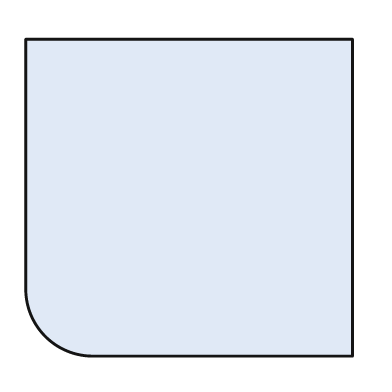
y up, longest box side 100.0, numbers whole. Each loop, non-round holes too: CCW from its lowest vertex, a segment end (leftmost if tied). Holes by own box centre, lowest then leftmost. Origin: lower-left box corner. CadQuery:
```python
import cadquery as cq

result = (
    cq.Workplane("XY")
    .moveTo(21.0, 0.0)
    .lineTo(100.0, 0.0)
    .lineTo(100.0, 97.0)
    .lineTo(0.0, 97.0)
    .lineTo(0.0, 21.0)
    .threePointArc((6.0, 6.0), (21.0, 0.0))
    .close()
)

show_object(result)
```